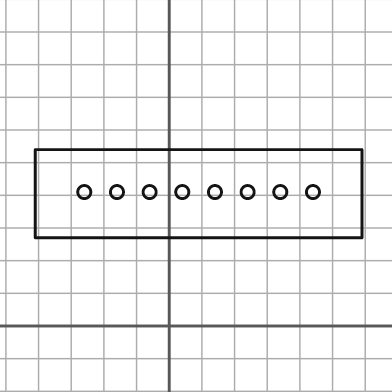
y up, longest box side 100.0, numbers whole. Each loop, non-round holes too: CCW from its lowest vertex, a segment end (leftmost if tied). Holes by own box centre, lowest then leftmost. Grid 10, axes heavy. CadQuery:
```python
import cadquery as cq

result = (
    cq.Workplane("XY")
    .moveTo(-41.0, 27.0)
    .lineTo(59.0, 27.0)
    .lineTo(59.0, 54.0)
    .lineTo(-41.0, 54.0)
    .close()
    .moveTo(-26.0, 41.0)
    .circle(2.0)
    .moveTo(-16.0, 41.0)
    .circle(2.0)
    .moveTo(-6.0, 41.0)
    .circle(2.0)
    .moveTo(4.0, 41.0)
    .circle(2.0)
    .moveTo(14.0, 41.0)
    .circle(2.0)
    .moveTo(24.0, 41.0)
    .circle(2.0)
    .moveTo(34.0, 41.0)
    .circle(2.0)
    .moveTo(44.0, 41.0)
    .circle(2.0)
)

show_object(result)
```